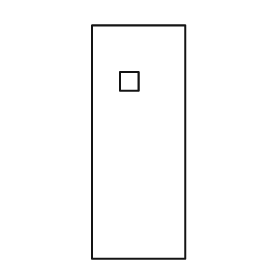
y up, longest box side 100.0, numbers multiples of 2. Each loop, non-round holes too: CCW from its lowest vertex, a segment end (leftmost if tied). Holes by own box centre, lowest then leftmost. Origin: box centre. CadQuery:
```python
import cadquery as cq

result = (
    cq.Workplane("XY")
    .moveTo(-20.0, -50.0)
    .lineTo(20.0, -50.0)
    .lineTo(20.0, 50.0)
    .lineTo(-20.0, 50.0)
    .close()
    .moveTo(-8.0, 22.0)
    .lineTo(0.0, 22.0)
    .lineTo(0.0, 30.0)
    .lineTo(-8.0, 30.0)
    .close()
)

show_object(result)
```